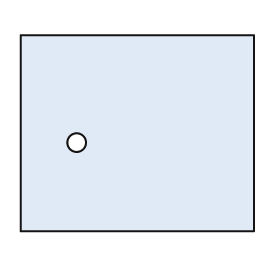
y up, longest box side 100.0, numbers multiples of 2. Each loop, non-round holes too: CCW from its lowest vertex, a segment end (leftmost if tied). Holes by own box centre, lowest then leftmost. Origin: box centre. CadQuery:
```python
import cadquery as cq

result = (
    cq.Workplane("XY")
    .moveTo(-50.0, -42.0)
    .lineTo(50.0, -42.0)
    .lineTo(50.0, 42.0)
    .lineTo(-50.0, 42.0)
    .close()
    .moveTo(-26.0, -4.0)
    .circle(4.0)
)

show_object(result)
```